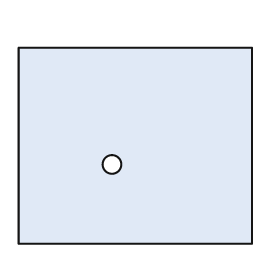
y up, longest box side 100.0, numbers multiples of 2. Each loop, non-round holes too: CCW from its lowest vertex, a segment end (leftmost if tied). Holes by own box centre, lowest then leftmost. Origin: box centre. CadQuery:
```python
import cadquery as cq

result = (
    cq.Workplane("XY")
    .moveTo(-50.0, -42.0)
    .lineTo(50.0, -42.0)
    .lineTo(50.0, 42.0)
    .lineTo(-50.0, 42.0)
    .close()
    .moveTo(-10.0, -8.0)
    .circle(4.0)
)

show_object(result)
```